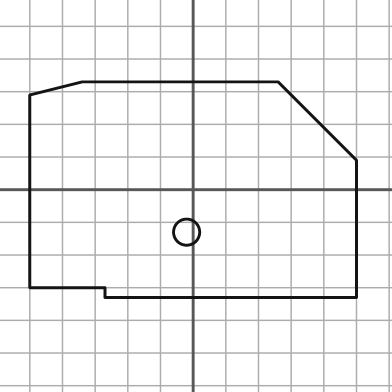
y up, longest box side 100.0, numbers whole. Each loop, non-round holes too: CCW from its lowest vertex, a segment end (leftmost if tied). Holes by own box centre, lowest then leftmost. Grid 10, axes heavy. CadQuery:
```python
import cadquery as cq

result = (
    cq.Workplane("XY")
    .moveTo(-27.0, -33.0)
    .lineTo(50.0, -33.0)
    .lineTo(50.0, 9.0)
    .lineTo(26.0, 33.0)
    .lineTo(-34.0, 33.0)
    .lineTo(-50.0, 29.0)
    .lineTo(-50.0, -30.0)
    .lineTo(-27.0, -30.0)
    .close()
    .moveTo(-2.0, -13.0)
    .circle(4.0)
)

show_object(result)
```